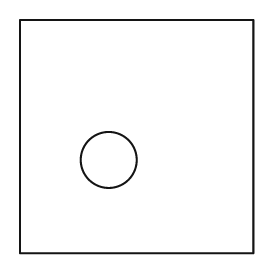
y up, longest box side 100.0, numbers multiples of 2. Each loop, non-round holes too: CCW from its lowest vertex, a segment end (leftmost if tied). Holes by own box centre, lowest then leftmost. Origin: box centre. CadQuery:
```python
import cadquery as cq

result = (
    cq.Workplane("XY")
    .moveTo(-50.0, -50.0)
    .lineTo(50.0, -50.0)
    .lineTo(50.0, 50.0)
    .lineTo(-50.0, 50.0)
    .close()
    .moveTo(-12.0, -10.0)
    .circle(12.0)
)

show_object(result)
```